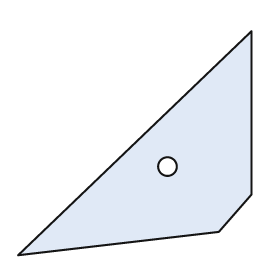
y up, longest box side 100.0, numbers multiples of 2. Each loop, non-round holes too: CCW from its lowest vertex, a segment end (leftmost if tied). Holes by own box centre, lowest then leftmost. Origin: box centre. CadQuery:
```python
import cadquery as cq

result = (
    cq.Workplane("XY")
    .moveTo(-50.0, -48.0)
    .lineTo(36.0, -38.0)
    .lineTo(50.0, -22.0)
    .lineTo(50.0, 48.0)
    .close()
    .moveTo(14.0, -10.0)
    .circle(4.0)
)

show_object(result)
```